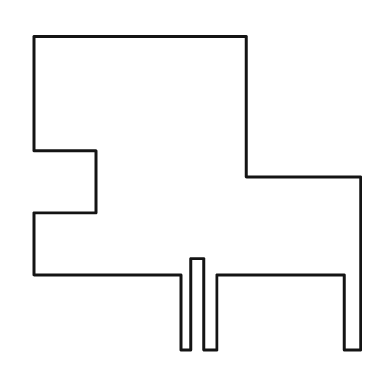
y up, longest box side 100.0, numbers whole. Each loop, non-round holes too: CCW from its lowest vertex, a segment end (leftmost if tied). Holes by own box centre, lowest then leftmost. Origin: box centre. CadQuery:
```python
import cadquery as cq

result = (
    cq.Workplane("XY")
    .moveTo(-5.0, -48.0)
    .lineTo(-2.0, -48.0)
    .lineTo(-2.0, -20.0)
    .lineTo(2.0, -20.0)
    .lineTo(2.0, -48.0)
    .lineTo(6.0, -48.0)
    .lineTo(6.0, -25.0)
    .lineTo(45.0, -25.0)
    .lineTo(45.0, -48.0)
    .lineTo(50.0, -48.0)
    .lineTo(50.0, 5.0)
    .lineTo(15.0, 5.0)
    .lineTo(15.0, 48.0)
    .lineTo(-50.0, 48.0)
    .lineTo(-50.0, 13.0)
    .lineTo(-31.0, 13.0)
    .lineTo(-31.0, -6.0)
    .lineTo(-50.0, -6.0)
    .lineTo(-50.0, -25.0)
    .lineTo(-5.0, -25.0)
    .close()
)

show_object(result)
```